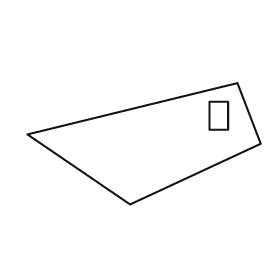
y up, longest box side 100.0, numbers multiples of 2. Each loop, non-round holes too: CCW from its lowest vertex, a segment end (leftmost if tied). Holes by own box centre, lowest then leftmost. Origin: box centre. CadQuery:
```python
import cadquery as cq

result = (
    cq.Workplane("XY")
    .moveTo(-6.0, -26.0)
    .lineTo(50.0, 0.0)
    .lineTo(40.0, 26.0)
    .lineTo(-50.0, 4.0)
    .close()
    .moveTo(28.0, 6.0)
    .lineTo(36.0, 6.0)
    .lineTo(36.0, 18.0)
    .lineTo(28.0, 18.0)
    .close()
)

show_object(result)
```